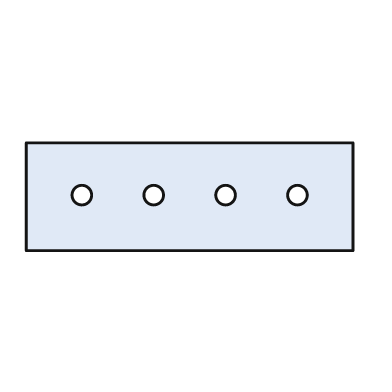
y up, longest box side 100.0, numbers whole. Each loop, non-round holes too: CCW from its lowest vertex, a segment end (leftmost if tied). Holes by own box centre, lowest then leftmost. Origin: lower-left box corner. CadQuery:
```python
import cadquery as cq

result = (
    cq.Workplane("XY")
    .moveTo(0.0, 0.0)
    .lineTo(100.0, 0.0)
    .lineTo(100.0, 33.0)
    .lineTo(0.0, 33.0)
    .close()
    .moveTo(17.0, 17.0)
    .circle(3.0)
    .moveTo(39.0, 17.0)
    .circle(3.0)
    .moveTo(61.0, 17.0)
    .circle(3.0)
    .moveTo(83.0, 17.0)
    .circle(3.0)
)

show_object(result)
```